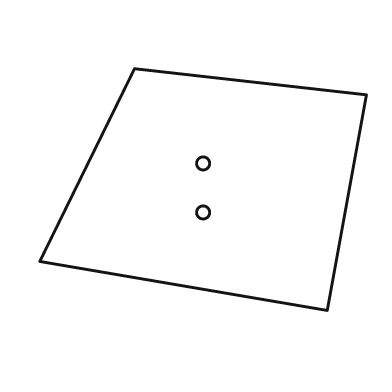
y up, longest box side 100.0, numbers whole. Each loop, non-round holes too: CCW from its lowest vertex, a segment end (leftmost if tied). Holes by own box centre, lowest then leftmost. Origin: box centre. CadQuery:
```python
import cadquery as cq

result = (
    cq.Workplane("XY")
    .moveTo(38.0, -37.0)
    .lineTo(50.0, 29.0)
    .lineTo(-21.0, 37.0)
    .lineTo(-50.0, -22.0)
    .close()
    .moveTo(0.0, -7.0)
    .circle(2.0)
    .moveTo(0.0, 8.0)
    .circle(2.0)
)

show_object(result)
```